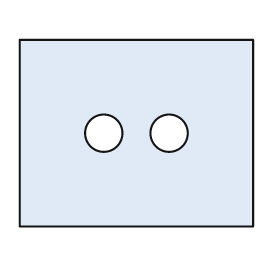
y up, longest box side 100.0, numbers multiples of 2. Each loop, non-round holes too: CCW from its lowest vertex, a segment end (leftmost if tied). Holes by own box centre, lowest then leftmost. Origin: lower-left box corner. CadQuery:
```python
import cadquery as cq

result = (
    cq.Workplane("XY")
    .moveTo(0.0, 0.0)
    .lineTo(100.0, 0.0)
    .lineTo(100.0, 80.0)
    .lineTo(0.0, 80.0)
    .close()
    .moveTo(36.0, 40.0)
    .circle(8.0)
    .moveTo(64.0, 40.0)
    .circle(8.0)
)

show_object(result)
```